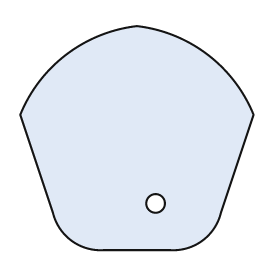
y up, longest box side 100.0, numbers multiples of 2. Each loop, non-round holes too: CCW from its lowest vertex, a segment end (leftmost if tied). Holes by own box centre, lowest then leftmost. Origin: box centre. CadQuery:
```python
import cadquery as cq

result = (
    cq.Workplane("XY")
    .moveTo(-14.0, -48.0)
    .lineTo(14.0, -48.0)
    .threePointArc((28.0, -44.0), (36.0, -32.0))
    .lineTo(50.0, 10.0)
    .threePointArc((30.0, 36.0), (0.0, 48.0))
    .threePointArc((-30.0, 36.0), (-50.0, 10.0))
    .lineTo(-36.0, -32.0)
    .threePointArc((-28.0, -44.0), (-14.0, -48.0))
    .close()
    .moveTo(8.0, -28.0)
    .circle(4.0)
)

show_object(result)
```